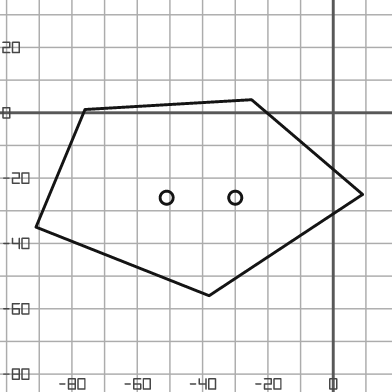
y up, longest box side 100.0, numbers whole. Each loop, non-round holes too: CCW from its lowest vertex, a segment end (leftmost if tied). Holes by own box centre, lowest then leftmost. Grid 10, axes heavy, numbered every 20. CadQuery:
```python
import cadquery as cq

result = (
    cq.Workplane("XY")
    .moveTo(-38.0, -56.0)
    .lineTo(9.0, -25.0)
    .lineTo(-25.0, 4.0)
    .lineTo(-76.0, 1.0)
    .lineTo(-91.0, -35.0)
    .close()
    .moveTo(-51.0, -26.0)
    .circle(2.0)
    .moveTo(-30.0, -26.0)
    .circle(2.0)
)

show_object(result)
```